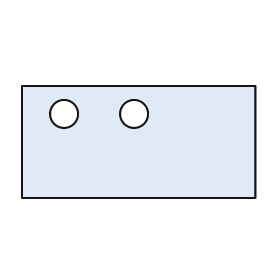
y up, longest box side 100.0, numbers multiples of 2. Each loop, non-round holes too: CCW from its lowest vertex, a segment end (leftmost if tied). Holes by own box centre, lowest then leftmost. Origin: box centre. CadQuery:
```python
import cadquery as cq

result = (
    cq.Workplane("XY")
    .moveTo(-50.0, -24.0)
    .lineTo(50.0, -24.0)
    .lineTo(50.0, 24.0)
    .lineTo(-50.0, 24.0)
    .close()
    .moveTo(-32.0, 12.0)
    .circle(6.0)
    .moveTo(-2.0, 12.0)
    .circle(6.0)
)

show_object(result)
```